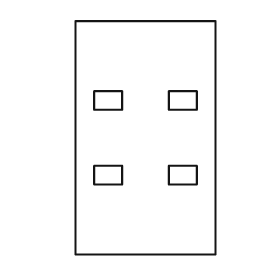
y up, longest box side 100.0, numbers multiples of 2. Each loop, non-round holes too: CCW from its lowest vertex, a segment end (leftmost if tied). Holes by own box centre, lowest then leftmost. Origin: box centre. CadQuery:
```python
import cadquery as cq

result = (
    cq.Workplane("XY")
    .moveTo(-30.0, -50.0)
    .lineTo(30.0, -50.0)
    .lineTo(30.0, 50.0)
    .lineTo(-30.0, 50.0)
    .close()
    .moveTo(-22.0, -20.0)
    .lineTo(-10.0, -20.0)
    .lineTo(-10.0, -12.0)
    .lineTo(-22.0, -12.0)
    .close()
    .moveTo(10.0, -20.0)
    .lineTo(22.0, -20.0)
    .lineTo(22.0, -12.0)
    .lineTo(10.0, -12.0)
    .close()
    .moveTo(-22.0, 12.0)
    .lineTo(-10.0, 12.0)
    .lineTo(-10.0, 20.0)
    .lineTo(-22.0, 20.0)
    .close()
    .moveTo(10.0, 12.0)
    .lineTo(22.0, 12.0)
    .lineTo(22.0, 20.0)
    .lineTo(10.0, 20.0)
    .close()
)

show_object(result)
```